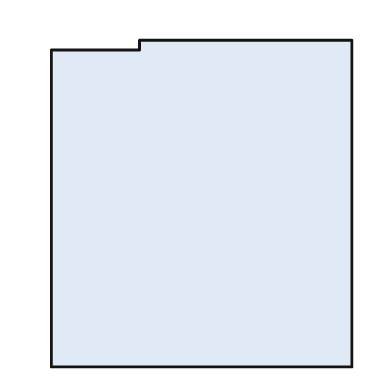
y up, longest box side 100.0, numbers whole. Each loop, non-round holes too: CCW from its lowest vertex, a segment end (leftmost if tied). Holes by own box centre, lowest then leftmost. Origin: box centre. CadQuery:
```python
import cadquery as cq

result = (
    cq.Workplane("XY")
    .moveTo(-46.0, -50.0)
    .lineTo(46.0, -50.0)
    .lineTo(46.0, 50.0)
    .lineTo(-19.0, 50.0)
    .lineTo(-19.0, 47.0)
    .lineTo(-46.0, 47.0)
    .close()
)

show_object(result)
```